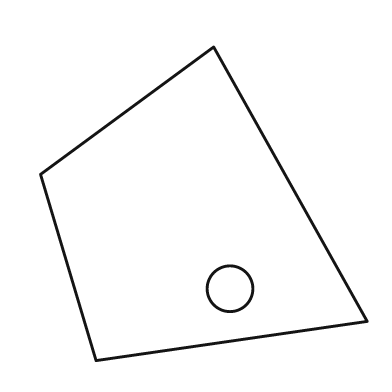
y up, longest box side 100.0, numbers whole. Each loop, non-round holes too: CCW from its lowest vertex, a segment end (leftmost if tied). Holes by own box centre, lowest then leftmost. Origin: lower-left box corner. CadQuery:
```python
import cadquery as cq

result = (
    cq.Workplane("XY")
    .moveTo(17.0, 0.0)
    .lineTo(100.0, 12.0)
    .lineTo(53.0, 96.0)
    .lineTo(0.0, 57.0)
    .close()
    .moveTo(58.0, 22.0)
    .circle(7.0)
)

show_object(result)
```